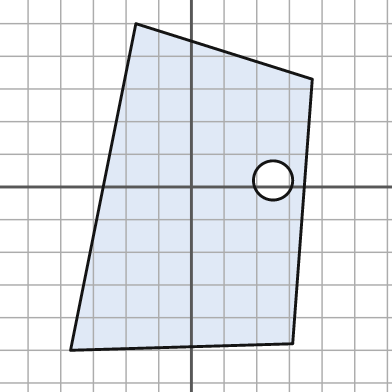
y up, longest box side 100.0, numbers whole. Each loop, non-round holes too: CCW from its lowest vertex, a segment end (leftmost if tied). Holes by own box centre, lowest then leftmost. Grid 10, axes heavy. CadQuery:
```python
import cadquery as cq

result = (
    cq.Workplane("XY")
    .moveTo(-37.0, -50.0)
    .lineTo(31.0, -48.0)
    .lineTo(37.0, 33.0)
    .lineTo(-17.0, 50.0)
    .close()
    .moveTo(25.0, 2.0)
    .circle(6.0)
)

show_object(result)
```